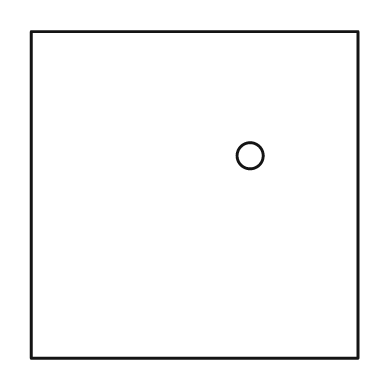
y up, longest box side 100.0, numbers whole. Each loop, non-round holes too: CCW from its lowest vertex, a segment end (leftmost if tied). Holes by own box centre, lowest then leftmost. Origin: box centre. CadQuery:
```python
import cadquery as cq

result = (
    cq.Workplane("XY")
    .moveTo(-50.0, -50.0)
    .lineTo(50.0, -50.0)
    .lineTo(50.0, 50.0)
    .lineTo(-50.0, 50.0)
    .close()
    .moveTo(17.0, 12.0)
    .circle(4.0)
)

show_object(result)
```